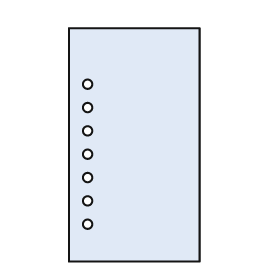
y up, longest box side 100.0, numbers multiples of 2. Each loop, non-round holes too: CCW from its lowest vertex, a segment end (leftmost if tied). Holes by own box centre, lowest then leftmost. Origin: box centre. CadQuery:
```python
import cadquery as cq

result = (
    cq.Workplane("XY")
    .moveTo(-28.0, -50.0)
    .lineTo(28.0, -50.0)
    .lineTo(28.0, 50.0)
    .lineTo(-28.0, 50.0)
    .close()
    .moveTo(-20.0, -34.0)
    .circle(2.0)
    .moveTo(-20.0, -24.0)
    .circle(2.0)
    .moveTo(-20.0, -14.0)
    .circle(2.0)
    .moveTo(-20.0, -4.0)
    .circle(2.0)
    .moveTo(-20.0, 6.0)
    .circle(2.0)
    .moveTo(-20.0, 16.0)
    .circle(2.0)
    .moveTo(-20.0, 26.0)
    .circle(2.0)
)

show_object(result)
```